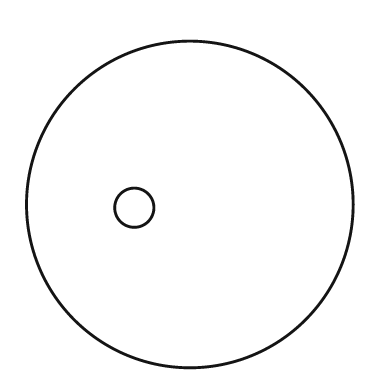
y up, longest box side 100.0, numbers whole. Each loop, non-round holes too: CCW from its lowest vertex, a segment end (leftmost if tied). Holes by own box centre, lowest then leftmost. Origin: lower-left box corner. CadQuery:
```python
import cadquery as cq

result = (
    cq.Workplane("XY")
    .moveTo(50.0, 50.0)
    .circle(50.0)
    .moveTo(33.0, 49.0)
    .circle(6.0)
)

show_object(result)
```